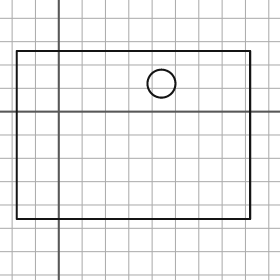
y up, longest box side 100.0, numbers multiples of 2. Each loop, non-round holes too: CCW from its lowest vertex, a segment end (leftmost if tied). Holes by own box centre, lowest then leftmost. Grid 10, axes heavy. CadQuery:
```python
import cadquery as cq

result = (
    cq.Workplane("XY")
    .moveTo(-18.0, -46.0)
    .lineTo(82.0, -46.0)
    .lineTo(82.0, 26.0)
    .lineTo(-18.0, 26.0)
    .close()
    .moveTo(44.0, 12.0)
    .circle(6.0)
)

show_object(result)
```